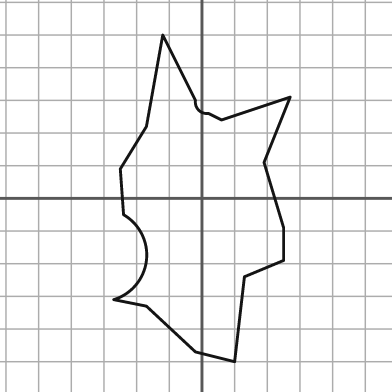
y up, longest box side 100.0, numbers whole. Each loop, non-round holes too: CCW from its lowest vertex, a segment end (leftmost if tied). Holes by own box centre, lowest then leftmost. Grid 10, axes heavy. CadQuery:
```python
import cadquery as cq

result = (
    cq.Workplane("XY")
    .moveTo(10.0, -50.0)
    .lineTo(13.0, -24.0)
    .lineTo(25.0, -19.0)
    .lineTo(25.0, -9.0)
    .lineTo(19.0, 11.0)
    .lineTo(27.0, 31.0)
    .lineTo(6.0, 24.0)
    .lineTo(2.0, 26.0)
    .threePointArc((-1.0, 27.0), (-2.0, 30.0))
    .lineTo(-12.0, 50.0)
    .lineTo(-17.0, 22.0)
    .lineTo(-25.0, 9.0)
    .lineTo(-24.0, -5.0)
    .threePointArc((-17.0, -19.0), (-27.0, -31.0))
    .lineTo(-17.0, -33.0)
    .lineTo(-2.0, -47.0)
    .close()
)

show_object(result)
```